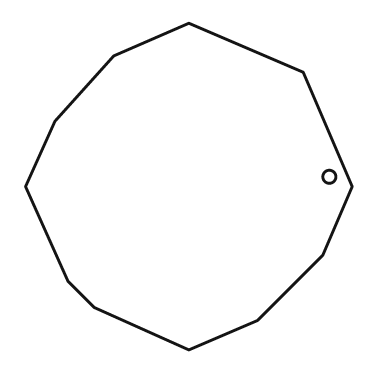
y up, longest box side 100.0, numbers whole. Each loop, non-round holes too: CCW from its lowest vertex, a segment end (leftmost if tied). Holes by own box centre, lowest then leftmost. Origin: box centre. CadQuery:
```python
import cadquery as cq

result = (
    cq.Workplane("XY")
    .moveTo(0.0, -50.0)
    .lineTo(21.0, -41.0)
    .lineTo(41.0, -21.0)
    .lineTo(50.0, 0.0)
    .lineTo(35.0, 35.0)
    .lineTo(0.0, 50.0)
    .lineTo(-23.0, 40.0)
    .lineTo(-41.0, 20.0)
    .lineTo(-50.0, 0.0)
    .lineTo(-37.0, -29.0)
    .lineTo(-29.0, -37.0)
    .close()
    .moveTo(43.0, 3.0)
    .circle(2.0)
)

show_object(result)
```